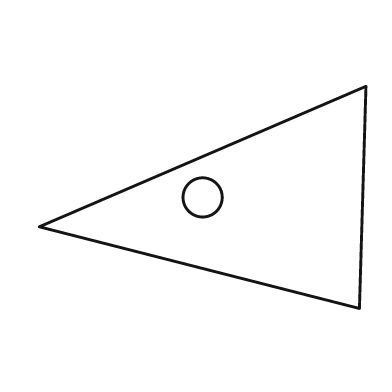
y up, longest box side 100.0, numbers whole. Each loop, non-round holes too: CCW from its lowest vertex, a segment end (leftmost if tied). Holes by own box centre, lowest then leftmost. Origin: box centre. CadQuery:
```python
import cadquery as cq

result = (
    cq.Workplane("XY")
    .moveTo(48.0, -34.0)
    .lineTo(50.0, 34.0)
    .lineTo(-50.0, -9.0)
    .close()
    .moveTo(0.0, 0.0)
    .circle(6.0)
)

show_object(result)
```